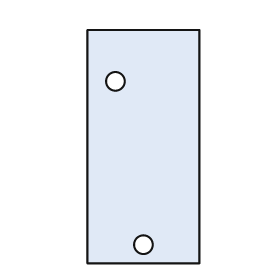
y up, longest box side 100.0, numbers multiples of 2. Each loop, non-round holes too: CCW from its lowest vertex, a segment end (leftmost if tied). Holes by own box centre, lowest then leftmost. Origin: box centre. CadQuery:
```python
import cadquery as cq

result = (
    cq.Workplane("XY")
    .moveTo(-24.0, -50.0)
    .lineTo(24.0, -50.0)
    .lineTo(24.0, 50.0)
    .lineTo(-24.0, 50.0)
    .close()
    .moveTo(0.0, -42.0)
    .circle(4.0)
    .moveTo(-12.0, 28.0)
    .circle(4.0)
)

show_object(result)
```